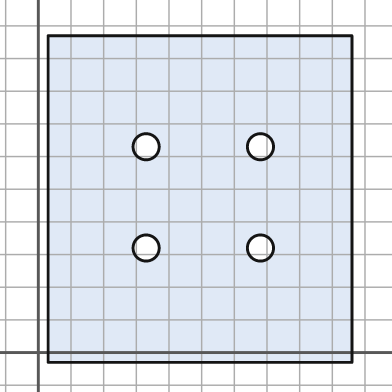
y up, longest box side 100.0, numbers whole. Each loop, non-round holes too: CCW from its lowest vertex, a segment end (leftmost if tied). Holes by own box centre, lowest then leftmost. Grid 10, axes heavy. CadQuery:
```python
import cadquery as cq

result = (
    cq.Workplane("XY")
    .moveTo(3.0, -3.0)
    .lineTo(96.0, -3.0)
    .lineTo(96.0, 97.0)
    .lineTo(3.0, 97.0)
    .close()
    .moveTo(33.0, 32.0)
    .circle(4.0)
    .moveTo(68.0, 32.0)
    .circle(4.0)
    .moveTo(33.0, 63.0)
    .circle(4.0)
    .moveTo(68.0, 63.0)
    .circle(4.0)
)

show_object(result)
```